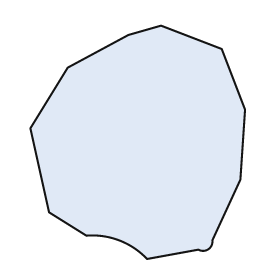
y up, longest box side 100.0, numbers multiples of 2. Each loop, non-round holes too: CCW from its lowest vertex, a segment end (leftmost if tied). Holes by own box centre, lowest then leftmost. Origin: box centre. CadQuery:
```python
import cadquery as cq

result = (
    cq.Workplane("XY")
    .moveTo(4.0, -50.0)
    .lineTo(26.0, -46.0)
    .threePointArc((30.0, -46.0), (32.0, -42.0))
    .lineTo(44.0, -16.0)
    .lineTo(46.0, 14.0)
    .lineTo(36.0, 40.0)
    .lineTo(10.0, 50.0)
    .lineTo(-4.0, 46.0)
    .lineTo(-30.0, 32.0)
    .lineTo(-46.0, 6.0)
    .lineTo(-38.0, -30.0)
    .lineTo(-22.0, -40.0)
    .threePointArc((-8.0, -42.0), (4.0, -50.0))
    .close()
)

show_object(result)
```